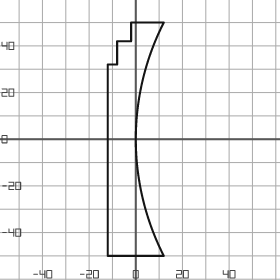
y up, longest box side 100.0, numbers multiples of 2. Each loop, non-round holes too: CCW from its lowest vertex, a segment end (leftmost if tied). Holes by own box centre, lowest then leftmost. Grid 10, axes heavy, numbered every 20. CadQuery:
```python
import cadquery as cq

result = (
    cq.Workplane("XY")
    .moveTo(-12.0, -50.0)
    .lineTo(12.0, -50.0)
    .threePointArc((0.0, 0.0), (12.0, 50.0))
    .lineTo(-2.0, 50.0)
    .lineTo(-2.0, 42.0)
    .lineTo(-8.0, 42.0)
    .lineTo(-8.0, 32.0)
    .lineTo(-12.0, 32.0)
    .close()
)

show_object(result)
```